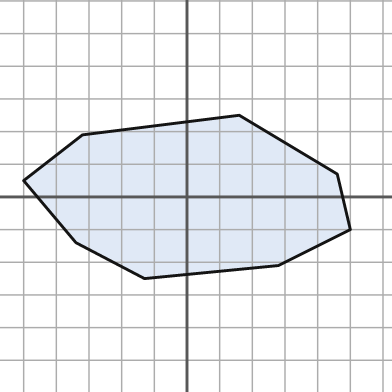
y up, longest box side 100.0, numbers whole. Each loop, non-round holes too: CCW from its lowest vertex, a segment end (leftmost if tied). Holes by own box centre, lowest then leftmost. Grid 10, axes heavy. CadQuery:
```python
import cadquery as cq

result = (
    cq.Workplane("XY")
    .moveTo(-13.0, -25.0)
    .lineTo(28.0, -21.0)
    .lineTo(50.0, -10.0)
    .lineTo(46.0, 7.0)
    .lineTo(16.0, 25.0)
    .lineTo(-32.0, 19.0)
    .lineTo(-50.0, 5.0)
    .lineTo(-34.0, -14.0)
    .close()
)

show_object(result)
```